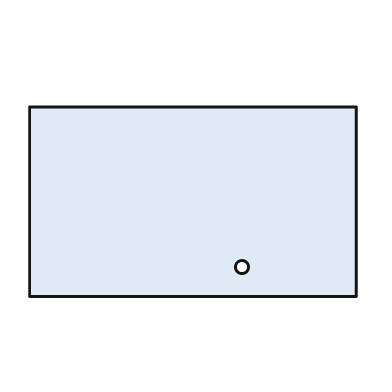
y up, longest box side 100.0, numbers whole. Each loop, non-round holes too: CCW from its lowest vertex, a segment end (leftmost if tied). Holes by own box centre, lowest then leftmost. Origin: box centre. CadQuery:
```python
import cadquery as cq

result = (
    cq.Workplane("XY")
    .moveTo(-50.0, -29.0)
    .lineTo(50.0, -29.0)
    .lineTo(50.0, 29.0)
    .lineTo(-50.0, 29.0)
    .close()
    .moveTo(15.0, -20.0)
    .circle(2.0)
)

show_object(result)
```